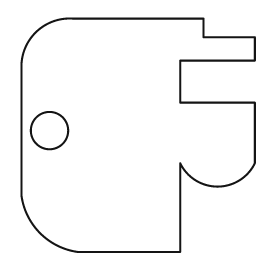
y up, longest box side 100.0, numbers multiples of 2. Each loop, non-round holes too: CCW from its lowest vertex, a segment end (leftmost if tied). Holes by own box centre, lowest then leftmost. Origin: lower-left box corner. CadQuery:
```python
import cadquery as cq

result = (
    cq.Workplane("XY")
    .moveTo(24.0, 0.0)
    .lineTo(68.0, 0.0)
    .lineTo(68.0, 38.0)
    .threePointArc((84.0, 28.0), (100.0, 38.0))
    .lineTo(100.0, 64.0)
    .lineTo(68.0, 64.0)
    .lineTo(68.0, 82.0)
    .lineTo(100.0, 82.0)
    .lineTo(100.0, 92.0)
    .lineTo(78.0, 92.0)
    .lineTo(78.0, 100.0)
    .lineTo(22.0, 100.0)
    .threePointArc((6.0, 94.0), (0.0, 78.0))
    .lineTo(0.0, 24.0)
    .threePointArc((8.0, 8.0), (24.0, 0.0))
    .close()
    .moveTo(12.0, 52.0)
    .circle(8.0)
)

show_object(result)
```